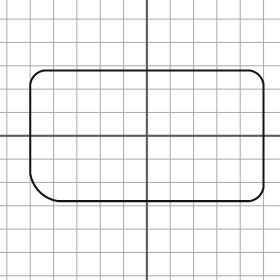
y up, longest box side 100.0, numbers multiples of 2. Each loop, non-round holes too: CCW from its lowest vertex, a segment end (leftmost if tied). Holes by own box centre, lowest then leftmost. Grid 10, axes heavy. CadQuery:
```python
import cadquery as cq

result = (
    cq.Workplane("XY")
    .moveTo(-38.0, -28.0)
    .lineTo(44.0, -28.0)
    .threePointArc((48.0, -26.0), (50.0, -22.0))
    .lineTo(50.0, 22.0)
    .threePointArc((48.0, 26.0), (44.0, 28.0))
    .lineTo(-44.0, 28.0)
    .threePointArc((-48.0, 26.0), (-50.0, 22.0))
    .lineTo(-50.0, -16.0)
    .threePointArc((-46.0, -24.0), (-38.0, -28.0))
    .close()
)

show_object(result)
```